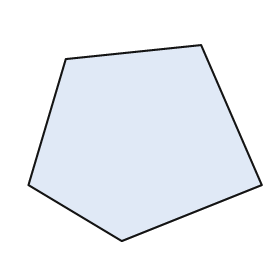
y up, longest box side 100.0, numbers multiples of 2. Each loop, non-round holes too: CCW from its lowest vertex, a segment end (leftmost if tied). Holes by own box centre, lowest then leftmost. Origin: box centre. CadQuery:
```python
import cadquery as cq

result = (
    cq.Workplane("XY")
    .moveTo(-10.0, -42.0)
    .lineTo(50.0, -18.0)
    .lineTo(24.0, 42.0)
    .lineTo(-34.0, 36.0)
    .lineTo(-50.0, -18.0)
    .close()
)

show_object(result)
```